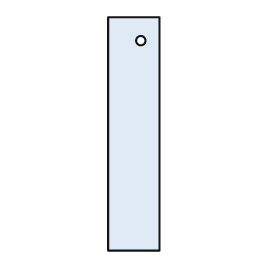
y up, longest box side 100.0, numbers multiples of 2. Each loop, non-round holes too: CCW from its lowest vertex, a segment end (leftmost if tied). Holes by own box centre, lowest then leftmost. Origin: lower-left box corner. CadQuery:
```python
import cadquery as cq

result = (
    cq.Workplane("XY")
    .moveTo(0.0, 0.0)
    .lineTo(22.0, 0.0)
    .lineTo(22.0, 100.0)
    .lineTo(0.0, 100.0)
    .close()
    .moveTo(14.0, 90.0)
    .circle(2.0)
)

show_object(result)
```